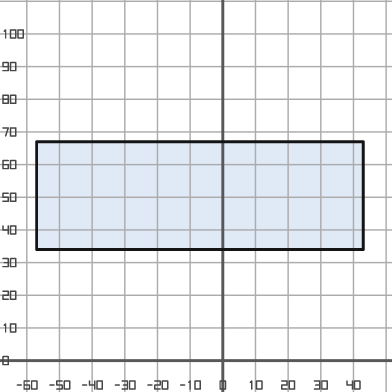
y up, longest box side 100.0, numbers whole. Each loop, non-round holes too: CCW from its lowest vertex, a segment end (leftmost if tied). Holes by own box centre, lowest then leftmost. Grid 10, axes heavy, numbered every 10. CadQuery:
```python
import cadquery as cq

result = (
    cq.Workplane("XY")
    .moveTo(-57.0, 34.0)
    .lineTo(43.0, 34.0)
    .lineTo(43.0, 67.0)
    .lineTo(-57.0, 67.0)
    .close()
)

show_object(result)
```